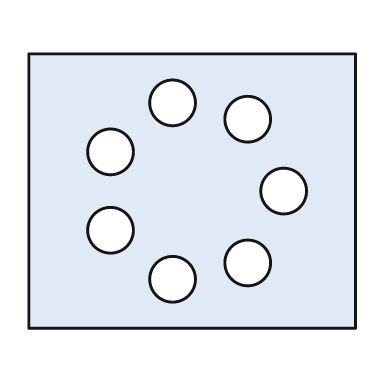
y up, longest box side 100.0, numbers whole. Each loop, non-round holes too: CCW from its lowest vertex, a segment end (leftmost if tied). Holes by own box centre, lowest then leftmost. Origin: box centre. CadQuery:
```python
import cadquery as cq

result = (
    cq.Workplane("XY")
    .moveTo(-50.0, -42.0)
    .lineTo(50.0, -42.0)
    .lineTo(50.0, 42.0)
    .lineTo(-50.0, 42.0)
    .close()
    .moveTo(-6.0, -27.0)
    .circle(7.0)
    .moveTo(17.0, -22.0)
    .circle(7.0)
    .moveTo(-25.0, -12.0)
    .circle(7.0)
    .moveTo(28.0, 0.0)
    .circle(7.0)
    .moveTo(-25.0, 12.0)
    .circle(7.0)
    .moveTo(17.0, 22.0)
    .circle(7.0)
    .moveTo(-6.0, 27.0)
    .circle(7.0)
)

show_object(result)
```